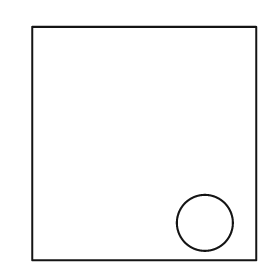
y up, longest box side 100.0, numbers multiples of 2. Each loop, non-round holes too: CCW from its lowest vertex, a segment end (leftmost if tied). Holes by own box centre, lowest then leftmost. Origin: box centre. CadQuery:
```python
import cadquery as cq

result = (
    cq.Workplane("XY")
    .moveTo(-48.0, -50.0)
    .lineTo(48.0, -50.0)
    .lineTo(48.0, 50.0)
    .lineTo(-48.0, 50.0)
    .close()
    .moveTo(26.0, -34.0)
    .circle(12.0)
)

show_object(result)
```